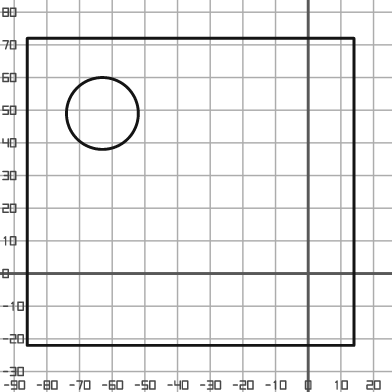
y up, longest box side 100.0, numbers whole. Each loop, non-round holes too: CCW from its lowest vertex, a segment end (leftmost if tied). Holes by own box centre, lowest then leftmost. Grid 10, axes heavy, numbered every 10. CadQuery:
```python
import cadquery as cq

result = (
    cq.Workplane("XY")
    .moveTo(-86.0, -22.0)
    .lineTo(14.0, -22.0)
    .lineTo(14.0, 72.0)
    .lineTo(-86.0, 72.0)
    .close()
    .moveTo(-63.0, 49.0)
    .circle(11.0)
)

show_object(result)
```